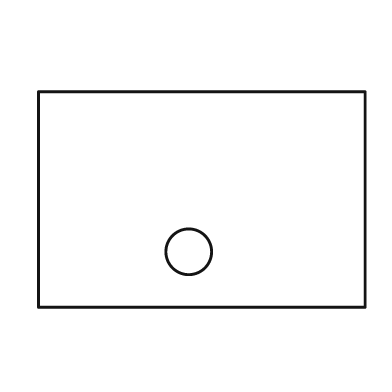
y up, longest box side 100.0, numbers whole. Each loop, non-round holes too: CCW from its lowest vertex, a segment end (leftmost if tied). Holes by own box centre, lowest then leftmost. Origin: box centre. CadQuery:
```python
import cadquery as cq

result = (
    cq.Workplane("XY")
    .moveTo(-50.0, -33.0)
    .lineTo(50.0, -33.0)
    .lineTo(50.0, 33.0)
    .lineTo(-50.0, 33.0)
    .close()
    .moveTo(-4.0, -16.0)
    .circle(7.0)
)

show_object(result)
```